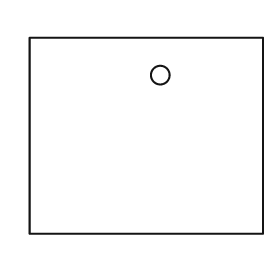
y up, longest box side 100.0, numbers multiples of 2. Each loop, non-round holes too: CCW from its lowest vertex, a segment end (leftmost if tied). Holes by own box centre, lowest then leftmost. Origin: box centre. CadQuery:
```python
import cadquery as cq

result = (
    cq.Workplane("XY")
    .moveTo(-50.0, -42.0)
    .lineTo(50.0, -42.0)
    .lineTo(50.0, 42.0)
    .lineTo(-50.0, 42.0)
    .close()
    .moveTo(6.0, 26.0)
    .circle(4.0)
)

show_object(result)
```